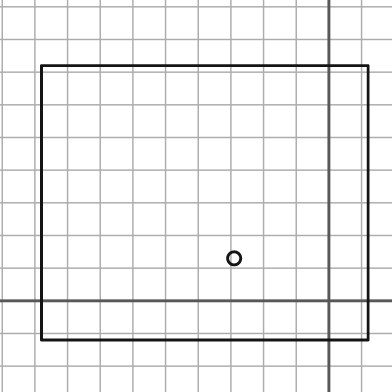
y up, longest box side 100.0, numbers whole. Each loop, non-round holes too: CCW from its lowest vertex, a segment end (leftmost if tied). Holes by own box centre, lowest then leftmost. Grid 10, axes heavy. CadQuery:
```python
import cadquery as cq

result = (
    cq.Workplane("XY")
    .moveTo(-88.0, -12.0)
    .lineTo(12.0, -12.0)
    .lineTo(12.0, 72.0)
    .lineTo(-88.0, 72.0)
    .close()
    .moveTo(-29.0, 13.0)
    .circle(2.0)
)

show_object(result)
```